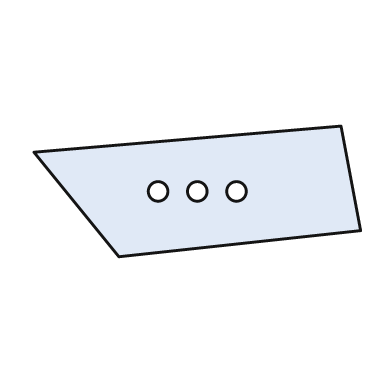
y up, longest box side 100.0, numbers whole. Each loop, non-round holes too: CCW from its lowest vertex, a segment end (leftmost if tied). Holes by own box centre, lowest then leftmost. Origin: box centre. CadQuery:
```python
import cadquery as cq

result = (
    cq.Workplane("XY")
    .moveTo(-24.0, -20.0)
    .lineTo(50.0, -12.0)
    .lineTo(44.0, 20.0)
    .lineTo(-50.0, 12.0)
    .close()
    .moveTo(-12.0, 0.0)
    .circle(3.0)
    .moveTo(0.0, 0.0)
    .circle(3.0)
    .moveTo(12.0, 0.0)
    .circle(3.0)
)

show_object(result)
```